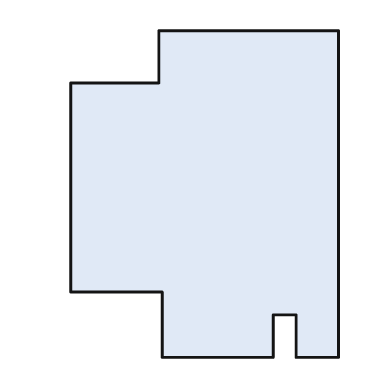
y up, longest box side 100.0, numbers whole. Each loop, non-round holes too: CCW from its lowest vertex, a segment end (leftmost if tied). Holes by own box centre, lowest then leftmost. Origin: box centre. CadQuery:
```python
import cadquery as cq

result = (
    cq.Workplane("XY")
    .moveTo(-13.0, -50.0)
    .lineTo(21.0, -50.0)
    .lineTo(21.0, -37.0)
    .lineTo(28.0, -37.0)
    .lineTo(28.0, -50.0)
    .lineTo(41.0, -50.0)
    .lineTo(41.0, 50.0)
    .lineTo(-14.0, 50.0)
    .lineTo(-14.0, 34.0)
    .lineTo(-41.0, 34.0)
    .lineTo(-41.0, -30.0)
    .lineTo(-13.0, -30.0)
    .close()
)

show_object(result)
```